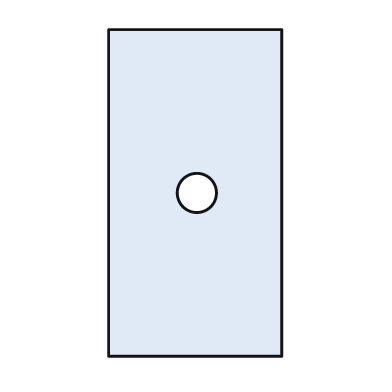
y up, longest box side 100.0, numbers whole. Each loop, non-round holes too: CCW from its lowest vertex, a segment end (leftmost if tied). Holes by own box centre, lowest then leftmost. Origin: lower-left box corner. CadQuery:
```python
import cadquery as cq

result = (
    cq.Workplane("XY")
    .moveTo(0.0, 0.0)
    .lineTo(53.0, 0.0)
    .lineTo(53.0, 100.0)
    .lineTo(0.0, 100.0)
    .close()
    .moveTo(27.0, 50.0)
    .circle(6.0)
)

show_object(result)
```